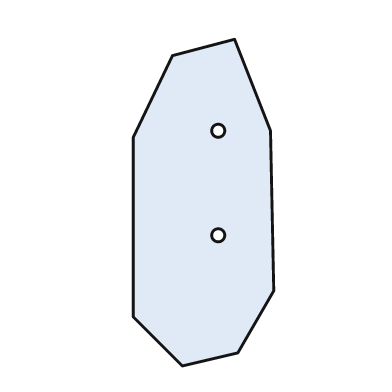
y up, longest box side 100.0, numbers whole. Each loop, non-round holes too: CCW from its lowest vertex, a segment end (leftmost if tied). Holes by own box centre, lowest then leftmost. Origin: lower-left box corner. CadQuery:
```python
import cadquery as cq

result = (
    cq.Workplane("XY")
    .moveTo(15.0, 0.0)
    .lineTo(32.0, 4.0)
    .lineTo(43.0, 23.0)
    .lineTo(42.0, 72.0)
    .lineTo(31.0, 100.0)
    .lineTo(12.0, 95.0)
    .lineTo(0.0, 70.0)
    .lineTo(0.0, 15.0)
    .close()
    .moveTo(26.0, 40.0)
    .circle(2.0)
    .moveTo(26.0, 72.0)
    .circle(2.0)
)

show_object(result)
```